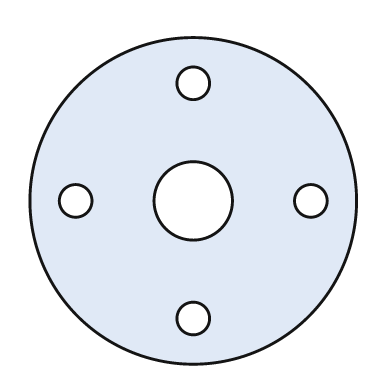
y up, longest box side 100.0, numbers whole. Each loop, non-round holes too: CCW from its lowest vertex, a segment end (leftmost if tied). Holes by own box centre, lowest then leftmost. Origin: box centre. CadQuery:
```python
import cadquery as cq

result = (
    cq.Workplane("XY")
    .moveTo(0.0, 0.0)
    .circle(50.0)
    .moveTo(0.0, -36.0)
    .circle(5.0)
    .moveTo(-36.0, 0.0)
    .circle(5.0)
    .moveTo(0.0, 0.0)
    .circle(12.0)
    .moveTo(36.0, 0.0)
    .circle(5.0)
    .moveTo(0.0, 36.0)
    .circle(5.0)
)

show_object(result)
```